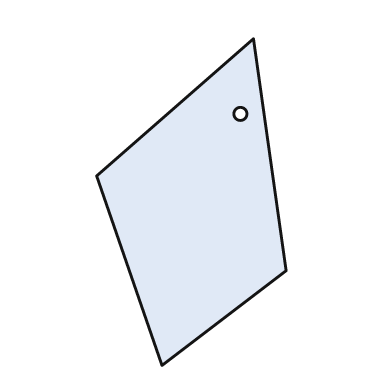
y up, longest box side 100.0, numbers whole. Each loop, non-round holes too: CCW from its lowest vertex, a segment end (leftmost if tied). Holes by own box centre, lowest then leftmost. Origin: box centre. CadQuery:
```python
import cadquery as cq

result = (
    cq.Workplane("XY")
    .moveTo(-9.0, -50.0)
    .lineTo(29.0, -21.0)
    .lineTo(19.0, 50.0)
    .lineTo(-29.0, 8.0)
    .close()
    .moveTo(15.0, 27.0)
    .circle(2.0)
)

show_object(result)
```